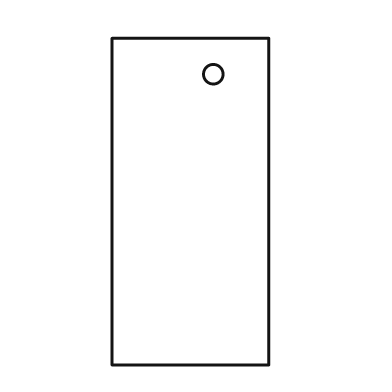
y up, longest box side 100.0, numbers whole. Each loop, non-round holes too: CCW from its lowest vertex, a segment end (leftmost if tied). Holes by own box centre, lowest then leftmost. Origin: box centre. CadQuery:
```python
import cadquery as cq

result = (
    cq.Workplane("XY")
    .moveTo(-24.0, -50.0)
    .lineTo(24.0, -50.0)
    .lineTo(24.0, 50.0)
    .lineTo(-24.0, 50.0)
    .close()
    .moveTo(7.0, 39.0)
    .circle(3.0)
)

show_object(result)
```